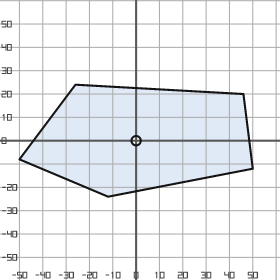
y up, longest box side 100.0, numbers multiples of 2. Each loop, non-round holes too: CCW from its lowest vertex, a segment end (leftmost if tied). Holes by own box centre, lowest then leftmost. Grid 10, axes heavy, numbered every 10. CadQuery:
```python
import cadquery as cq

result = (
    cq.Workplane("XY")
    .moveTo(-12.0, -24.0)
    .lineTo(50.0, -12.0)
    .lineTo(46.0, 20.0)
    .lineTo(-26.0, 24.0)
    .lineTo(-50.0, -8.0)
    .close()
    .moveTo(0.0, 0.0)
    .circle(2.0)
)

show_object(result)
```